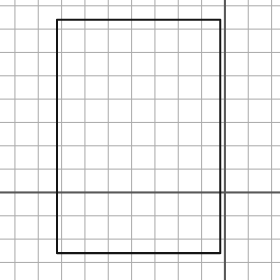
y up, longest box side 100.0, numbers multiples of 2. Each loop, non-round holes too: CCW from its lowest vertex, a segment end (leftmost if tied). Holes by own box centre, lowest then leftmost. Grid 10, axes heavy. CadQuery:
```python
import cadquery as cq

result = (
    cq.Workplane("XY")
    .moveTo(-72.0, -26.0)
    .lineTo(-2.0, -26.0)
    .lineTo(-2.0, 74.0)
    .lineTo(-72.0, 74.0)
    .close()
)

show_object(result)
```